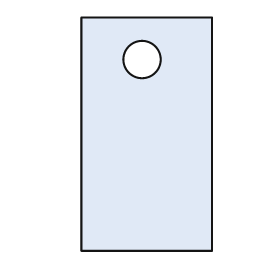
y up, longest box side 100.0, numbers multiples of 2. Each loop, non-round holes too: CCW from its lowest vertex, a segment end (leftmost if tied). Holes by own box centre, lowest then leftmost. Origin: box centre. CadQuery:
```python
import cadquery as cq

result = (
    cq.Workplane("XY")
    .moveTo(-28.0, -50.0)
    .lineTo(28.0, -50.0)
    .lineTo(28.0, 50.0)
    .lineTo(-28.0, 50.0)
    .close()
    .moveTo(-2.0, 32.0)
    .circle(8.0)
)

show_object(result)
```